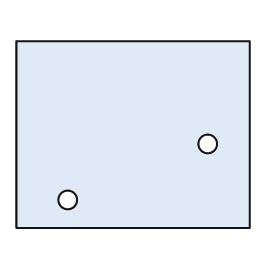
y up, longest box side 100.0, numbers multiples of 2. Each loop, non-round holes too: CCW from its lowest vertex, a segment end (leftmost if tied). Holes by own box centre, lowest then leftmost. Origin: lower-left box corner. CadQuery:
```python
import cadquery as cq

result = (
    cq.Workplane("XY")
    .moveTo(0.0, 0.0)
    .lineTo(100.0, 0.0)
    .lineTo(100.0, 80.0)
    .lineTo(0.0, 80.0)
    .close()
    .moveTo(22.0, 12.0)
    .circle(4.0)
    .moveTo(82.0, 36.0)
    .circle(4.0)
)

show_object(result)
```